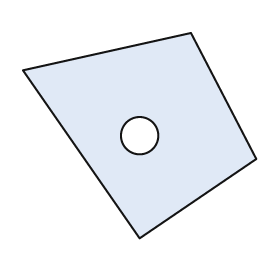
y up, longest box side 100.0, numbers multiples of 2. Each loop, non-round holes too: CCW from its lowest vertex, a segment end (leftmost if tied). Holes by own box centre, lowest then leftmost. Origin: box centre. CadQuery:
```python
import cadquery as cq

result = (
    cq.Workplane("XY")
    .moveTo(0.0, -44.0)
    .lineTo(50.0, -10.0)
    .lineTo(22.0, 44.0)
    .lineTo(-50.0, 28.0)
    .close()
    .moveTo(0.0, 0.0)
    .circle(8.0)
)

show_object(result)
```